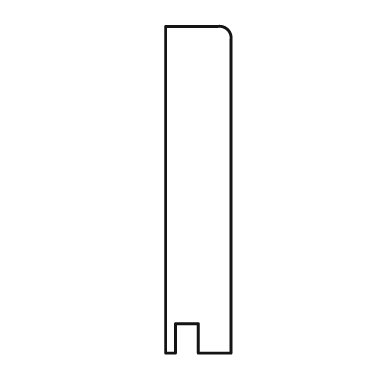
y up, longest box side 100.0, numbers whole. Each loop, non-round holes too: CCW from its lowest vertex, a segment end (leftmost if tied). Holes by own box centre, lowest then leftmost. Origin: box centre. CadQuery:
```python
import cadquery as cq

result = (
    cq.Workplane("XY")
    .moveTo(-10.0, -50.0)
    .lineTo(-7.0, -50.0)
    .lineTo(-7.0, -41.0)
    .lineTo(0.0, -41.0)
    .lineTo(0.0, -50.0)
    .lineTo(10.0, -50.0)
    .lineTo(10.0, 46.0)
    .threePointArc((9.0, 49.0), (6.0, 50.0))
    .lineTo(-10.0, 50.0)
    .close()
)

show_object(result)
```